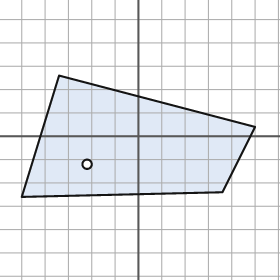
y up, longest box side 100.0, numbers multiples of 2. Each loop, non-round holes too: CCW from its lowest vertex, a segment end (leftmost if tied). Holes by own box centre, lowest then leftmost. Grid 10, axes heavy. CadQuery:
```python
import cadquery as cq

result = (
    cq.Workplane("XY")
    .moveTo(-50.0, -26.0)
    .lineTo(36.0, -24.0)
    .lineTo(50.0, 4.0)
    .lineTo(-34.0, 26.0)
    .close()
    .moveTo(-22.0, -12.0)
    .circle(2.0)
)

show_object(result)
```